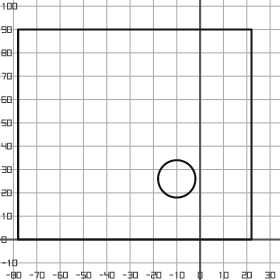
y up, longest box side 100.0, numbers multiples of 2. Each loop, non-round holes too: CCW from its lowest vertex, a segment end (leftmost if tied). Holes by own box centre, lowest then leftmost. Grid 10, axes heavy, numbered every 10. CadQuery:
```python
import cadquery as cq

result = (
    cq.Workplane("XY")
    .moveTo(-78.0, 0.0)
    .lineTo(22.0, 0.0)
    .lineTo(22.0, 90.0)
    .lineTo(-78.0, 90.0)
    .close()
    .moveTo(-10.0, 26.0)
    .circle(8.0)
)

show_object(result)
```